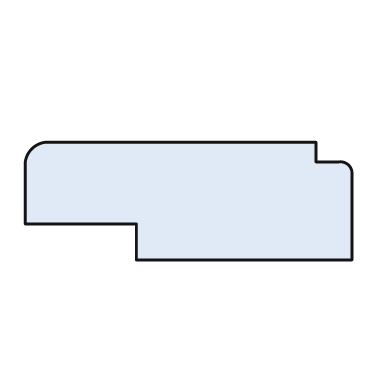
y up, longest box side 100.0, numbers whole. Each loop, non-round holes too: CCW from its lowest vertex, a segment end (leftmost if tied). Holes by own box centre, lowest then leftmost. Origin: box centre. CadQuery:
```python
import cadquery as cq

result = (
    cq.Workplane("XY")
    .moveTo(-16.0, -18.0)
    .lineTo(50.0, -18.0)
    .lineTo(50.0, 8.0)
    .threePointArc((49.0, 11.0), (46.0, 12.0))
    .lineTo(39.0, 12.0)
    .lineTo(39.0, 18.0)
    .lineTo(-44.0, 18.0)
    .threePointArc((-48.0, 16.0), (-50.0, 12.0))
    .lineTo(-50.0, -7.0)
    .lineTo(-16.0, -7.0)
    .close()
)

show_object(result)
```